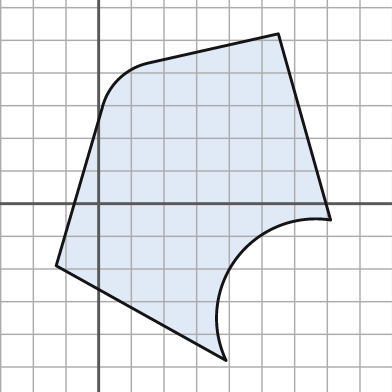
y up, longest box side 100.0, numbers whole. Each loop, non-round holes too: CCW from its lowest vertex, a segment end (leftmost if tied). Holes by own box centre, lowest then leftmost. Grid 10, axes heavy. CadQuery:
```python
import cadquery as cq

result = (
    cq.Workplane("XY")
    .moveTo(39.0, -48.0)
    .threePointArc((42.0, -17.0), (71.0, -5.0))
    .lineTo(55.0, 52.0)
    .lineTo(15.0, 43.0)
    .threePointArc((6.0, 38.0), (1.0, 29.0))
    .lineTo(-13.0, -19.0)
    .close()
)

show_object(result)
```